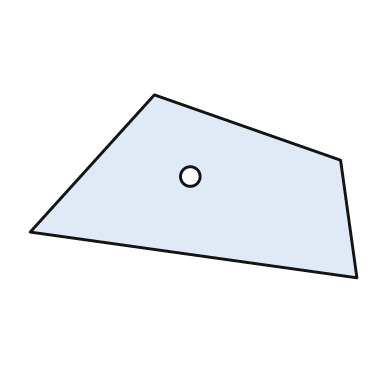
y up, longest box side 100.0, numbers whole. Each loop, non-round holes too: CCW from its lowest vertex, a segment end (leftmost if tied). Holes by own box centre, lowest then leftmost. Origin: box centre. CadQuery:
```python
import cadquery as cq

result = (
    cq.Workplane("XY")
    .moveTo(50.0, -28.0)
    .lineTo(45.0, 8.0)
    .lineTo(-12.0, 28.0)
    .lineTo(-50.0, -14.0)
    .close()
    .moveTo(-1.0, 3.0)
    .circle(3.0)
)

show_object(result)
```